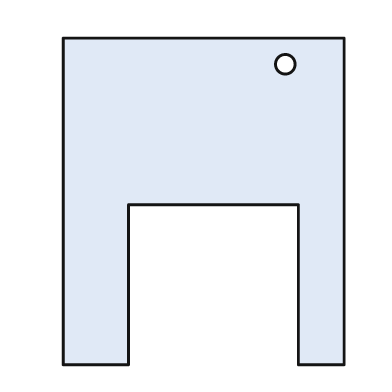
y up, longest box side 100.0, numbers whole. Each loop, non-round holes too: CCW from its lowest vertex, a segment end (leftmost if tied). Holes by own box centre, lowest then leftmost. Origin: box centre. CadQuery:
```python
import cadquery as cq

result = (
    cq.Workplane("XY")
    .moveTo(-43.0, -50.0)
    .lineTo(-23.0, -50.0)
    .lineTo(-23.0, -1.0)
    .lineTo(29.0, -1.0)
    .lineTo(29.0, -50.0)
    .lineTo(43.0, -50.0)
    .lineTo(43.0, 50.0)
    .lineTo(-43.0, 50.0)
    .close()
    .moveTo(25.0, 42.0)
    .circle(3.0)
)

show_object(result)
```